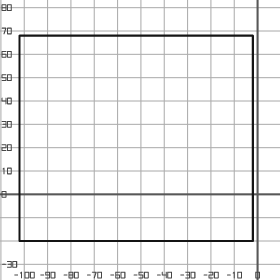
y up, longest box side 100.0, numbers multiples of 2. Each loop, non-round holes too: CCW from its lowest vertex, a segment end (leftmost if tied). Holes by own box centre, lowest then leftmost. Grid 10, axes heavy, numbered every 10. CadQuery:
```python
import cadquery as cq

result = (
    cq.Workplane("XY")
    .moveTo(-102.0, -20.0)
    .lineTo(-2.0, -20.0)
    .lineTo(-2.0, 68.0)
    .lineTo(-102.0, 68.0)
    .close()
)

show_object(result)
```